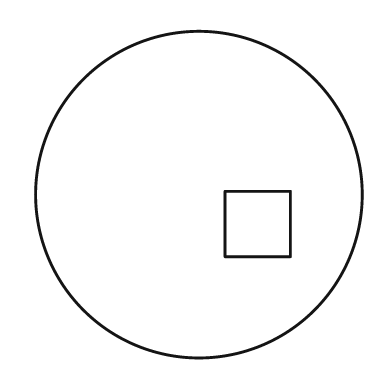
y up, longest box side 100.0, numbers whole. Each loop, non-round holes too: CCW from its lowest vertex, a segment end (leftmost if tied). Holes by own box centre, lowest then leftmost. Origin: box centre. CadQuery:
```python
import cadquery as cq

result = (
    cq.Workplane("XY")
    .moveTo(0.0, 0.0)
    .circle(50.0)
    .moveTo(8.0, -19.0)
    .lineTo(28.0, -19.0)
    .lineTo(28.0, 1.0)
    .lineTo(8.0, 1.0)
    .close()
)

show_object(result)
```